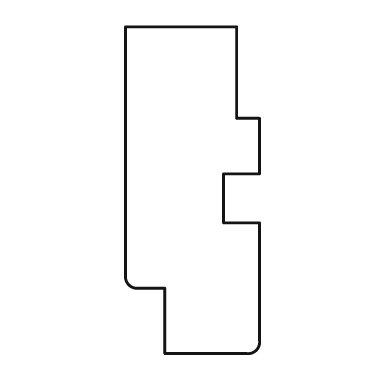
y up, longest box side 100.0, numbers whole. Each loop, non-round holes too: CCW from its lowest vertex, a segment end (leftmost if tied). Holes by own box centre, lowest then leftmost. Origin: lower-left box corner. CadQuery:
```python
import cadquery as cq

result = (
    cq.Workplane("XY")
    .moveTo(12.0, 0.0)
    .lineTo(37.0, 0.0)
    .threePointArc((40.0, 1.0), (41.0, 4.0))
    .lineTo(41.0, 40.0)
    .lineTo(30.0, 40.0)
    .lineTo(30.0, 55.0)
    .lineTo(41.0, 55.0)
    .lineTo(41.0, 72.0)
    .lineTo(34.0, 72.0)
    .lineTo(34.0, 100.0)
    .lineTo(0.0, 100.0)
    .lineTo(0.0, 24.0)
    .threePointArc((1.0, 21.0), (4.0, 20.0))
    .lineTo(12.0, 20.0)
    .close()
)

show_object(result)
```